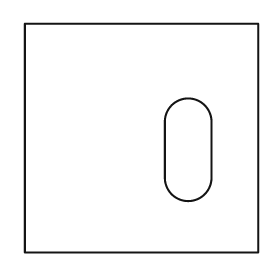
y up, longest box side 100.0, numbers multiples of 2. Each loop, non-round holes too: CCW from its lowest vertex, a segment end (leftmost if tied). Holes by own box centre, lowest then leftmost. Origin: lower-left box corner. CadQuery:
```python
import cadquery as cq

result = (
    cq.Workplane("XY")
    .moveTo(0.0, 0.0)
    .lineTo(100.0, 0.0)
    .lineTo(100.0, 98.0)
    .lineTo(0.0, 98.0)
    .close()
    .moveTo(60.0, 32.0)
    .threePointArc((70.0, 22.0), (80.0, 32.0))
    .lineTo(80.0, 56.0)
    .threePointArc((70.0, 66.0), (60.0, 56.0))
    .close()
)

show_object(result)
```